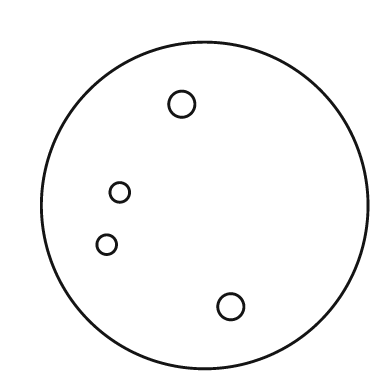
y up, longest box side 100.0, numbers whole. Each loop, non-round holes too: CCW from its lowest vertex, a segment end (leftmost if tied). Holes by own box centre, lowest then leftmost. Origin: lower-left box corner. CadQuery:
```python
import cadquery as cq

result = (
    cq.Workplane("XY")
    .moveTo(50.0, 50.0)
    .circle(50.0)
    .moveTo(58.0, 19.0)
    .circle(4.0)
    .moveTo(20.0, 38.0)
    .circle(3.0)
    .moveTo(24.0, 54.0)
    .circle(3.0)
    .moveTo(43.0, 81.0)
    .circle(4.0)
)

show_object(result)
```